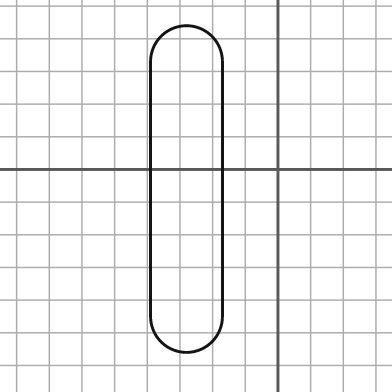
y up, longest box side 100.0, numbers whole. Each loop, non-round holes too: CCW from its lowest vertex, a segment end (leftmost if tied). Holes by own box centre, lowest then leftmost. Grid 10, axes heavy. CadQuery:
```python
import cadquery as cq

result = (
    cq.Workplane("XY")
    .moveTo(-39.0, -45.0)
    .threePointArc((-28.0, -56.0), (-17.0, -45.0))
    .lineTo(-17.0, 33.0)
    .threePointArc((-28.0, 44.0), (-39.0, 33.0))
    .close()
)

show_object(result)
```